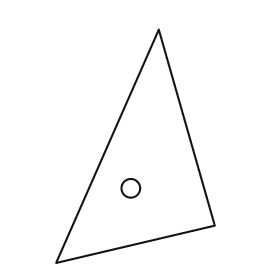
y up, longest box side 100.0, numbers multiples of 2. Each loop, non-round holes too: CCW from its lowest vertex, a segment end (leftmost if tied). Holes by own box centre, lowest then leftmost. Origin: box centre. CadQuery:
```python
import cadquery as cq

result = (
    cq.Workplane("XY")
    .moveTo(-34.0, -50.0)
    .lineTo(34.0, -34.0)
    .lineTo(10.0, 50.0)
    .close()
    .moveTo(-2.0, -18.0)
    .circle(4.0)
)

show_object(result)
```